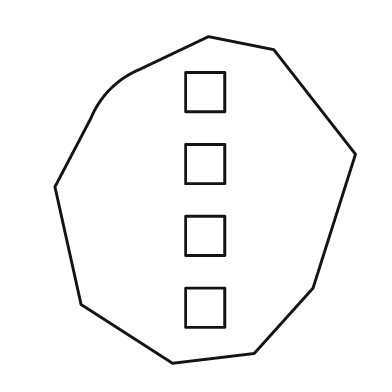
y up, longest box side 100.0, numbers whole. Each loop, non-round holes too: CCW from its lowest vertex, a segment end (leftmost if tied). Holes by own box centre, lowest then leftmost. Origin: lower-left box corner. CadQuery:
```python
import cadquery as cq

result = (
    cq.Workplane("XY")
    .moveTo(36.0, 0.0)
    .lineTo(61.0, 3.0)
    .lineTo(79.0, 23.0)
    .lineTo(92.0, 64.0)
    .lineTo(67.0, 96.0)
    .lineTo(47.0, 100.0)
    .lineTo(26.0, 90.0)
    .threePointArc((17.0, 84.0), (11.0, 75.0))
    .lineTo(0.0, 54.0)
    .lineTo(8.0, 18.0)
    .close()
    .moveTo(40.0, 11.0)
    .lineTo(52.0, 11.0)
    .lineTo(52.0, 23.0)
    .lineTo(40.0, 23.0)
    .close()
    .moveTo(40.0, 33.0)
    .lineTo(52.0, 33.0)
    .lineTo(52.0, 45.0)
    .lineTo(40.0, 45.0)
    .close()
    .moveTo(40.0, 55.0)
    .lineTo(52.0, 55.0)
    .lineTo(52.0, 67.0)
    .lineTo(40.0, 67.0)
    .close()
    .moveTo(40.0, 77.0)
    .lineTo(52.0, 77.0)
    .lineTo(52.0, 89.0)
    .lineTo(40.0, 89.0)
    .close()
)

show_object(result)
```